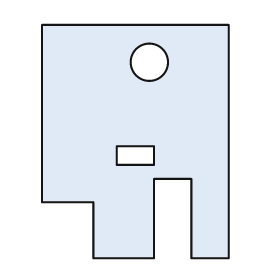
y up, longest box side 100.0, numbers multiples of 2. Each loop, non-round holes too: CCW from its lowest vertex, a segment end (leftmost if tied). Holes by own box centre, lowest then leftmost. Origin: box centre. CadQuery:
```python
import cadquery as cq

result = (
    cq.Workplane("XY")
    .moveTo(-18.0, -50.0)
    .lineTo(8.0, -50.0)
    .lineTo(8.0, -16.0)
    .lineTo(24.0, -16.0)
    .lineTo(24.0, -50.0)
    .lineTo(40.0, -50.0)
    .lineTo(40.0, 50.0)
    .lineTo(-40.0, 50.0)
    .lineTo(-40.0, -26.0)
    .lineTo(-18.0, -26.0)
    .close()
    .moveTo(-8.0, -10.0)
    .lineTo(8.0, -10.0)
    .lineTo(8.0, -2.0)
    .lineTo(-8.0, -2.0)
    .close()
    .moveTo(6.0, 34.0)
    .circle(8.0)
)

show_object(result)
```